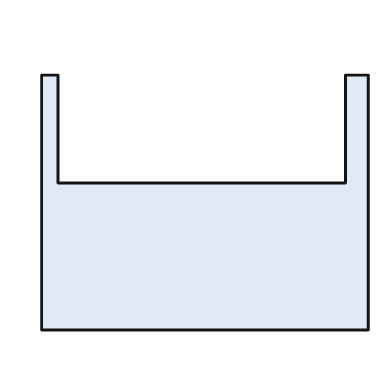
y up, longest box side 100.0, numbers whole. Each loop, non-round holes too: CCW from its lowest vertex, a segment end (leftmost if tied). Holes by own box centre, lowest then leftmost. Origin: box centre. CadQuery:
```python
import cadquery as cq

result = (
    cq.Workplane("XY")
    .moveTo(-50.0, -39.0)
    .lineTo(50.0, -39.0)
    .lineTo(50.0, 39.0)
    .lineTo(43.0, 39.0)
    .lineTo(43.0, 6.0)
    .lineTo(-45.0, 6.0)
    .lineTo(-45.0, 39.0)
    .lineTo(-50.0, 39.0)
    .close()
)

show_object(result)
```